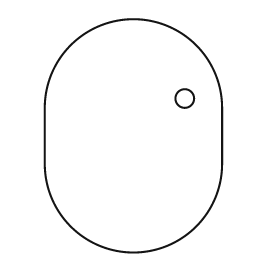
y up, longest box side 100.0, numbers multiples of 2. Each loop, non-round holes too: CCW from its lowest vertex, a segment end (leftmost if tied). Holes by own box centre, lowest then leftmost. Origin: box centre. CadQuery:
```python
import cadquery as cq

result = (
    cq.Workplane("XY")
    .moveTo(-38.0, -12.0)
    .threePointArc((0.0, -50.0), (38.0, -12.0))
    .lineTo(38.0, 12.0)
    .threePointArc((0.0, 50.0), (-38.0, 12.0))
    .close()
    .moveTo(22.0, 16.0)
    .circle(4.0)
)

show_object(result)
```